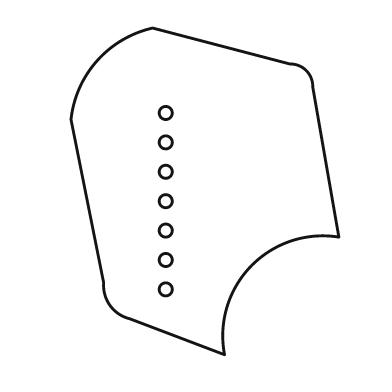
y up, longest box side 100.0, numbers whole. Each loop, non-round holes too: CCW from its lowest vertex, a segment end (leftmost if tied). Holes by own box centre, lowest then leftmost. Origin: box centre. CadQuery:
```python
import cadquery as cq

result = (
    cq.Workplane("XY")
    .moveTo(6.0, -50.0)
    .threePointArc((14.0, -23.0), (41.0, -14.0))
    .lineTo(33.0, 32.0)
    .threePointArc((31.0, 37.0), (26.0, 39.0))
    .lineTo(-16.0, 50.0)
    .threePointArc((-33.0, 40.0), (-41.0, 22.0))
    .lineTo(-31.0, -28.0)
    .threePointArc((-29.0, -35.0), (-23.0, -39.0))
    .close()
    .moveTo(-12.0, -30.0)
    .circle(2.0)
    .moveTo(-12.0, -21.0)
    .circle(2.0)
    .moveTo(-12.0, -12.0)
    .circle(2.0)
    .moveTo(-12.0, -3.0)
    .circle(2.0)
    .moveTo(-12.0, 6.0)
    .circle(2.0)
    .moveTo(-12.0, 15.0)
    .circle(2.0)
    .moveTo(-12.0, 24.0)
    .circle(2.0)
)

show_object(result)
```